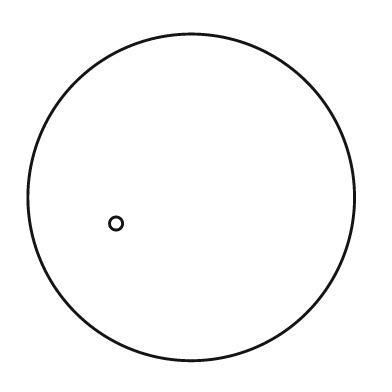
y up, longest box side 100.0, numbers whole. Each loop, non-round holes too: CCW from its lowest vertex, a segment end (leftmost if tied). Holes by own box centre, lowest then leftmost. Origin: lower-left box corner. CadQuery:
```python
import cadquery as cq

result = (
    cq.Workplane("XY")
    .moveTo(50.0, 50.0)
    .circle(50.0)
    .moveTo(27.0, 42.0)
    .circle(2.0)
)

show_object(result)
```